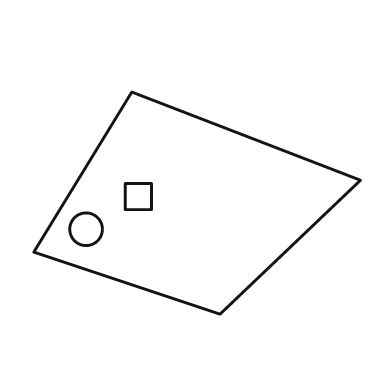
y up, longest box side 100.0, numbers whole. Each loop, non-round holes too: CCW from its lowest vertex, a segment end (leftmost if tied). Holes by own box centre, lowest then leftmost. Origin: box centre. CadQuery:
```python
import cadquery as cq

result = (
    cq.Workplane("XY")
    .moveTo(7.0, -34.0)
    .lineTo(50.0, 7.0)
    .lineTo(-20.0, 34.0)
    .lineTo(-50.0, -15.0)
    .close()
    .moveTo(-34.0, -8.0)
    .circle(5.0)
    .moveTo(-22.0, -2.0)
    .lineTo(-14.0, -2.0)
    .lineTo(-14.0, 6.0)
    .lineTo(-22.0, 6.0)
    .close()
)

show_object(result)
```